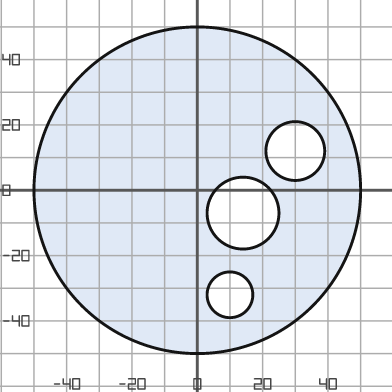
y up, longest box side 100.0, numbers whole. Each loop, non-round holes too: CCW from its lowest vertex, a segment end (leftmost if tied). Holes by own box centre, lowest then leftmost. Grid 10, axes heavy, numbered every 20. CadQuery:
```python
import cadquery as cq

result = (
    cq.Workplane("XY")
    .moveTo(0.0, 0.0)
    .circle(50.0)
    .moveTo(10.0, -32.0)
    .circle(7.0)
    .moveTo(14.0, -7.0)
    .circle(11.0)
    .moveTo(30.0, 12.0)
    .circle(9.0)
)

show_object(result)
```